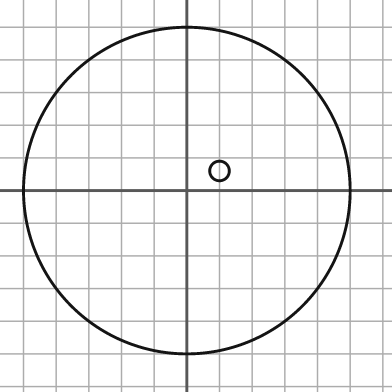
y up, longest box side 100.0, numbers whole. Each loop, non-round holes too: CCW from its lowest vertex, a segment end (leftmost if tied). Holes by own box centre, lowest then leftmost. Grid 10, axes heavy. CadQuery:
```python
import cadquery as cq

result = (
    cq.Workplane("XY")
    .moveTo(0.0, 0.0)
    .circle(50.0)
    .moveTo(10.0, 6.0)
    .circle(3.0)
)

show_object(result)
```